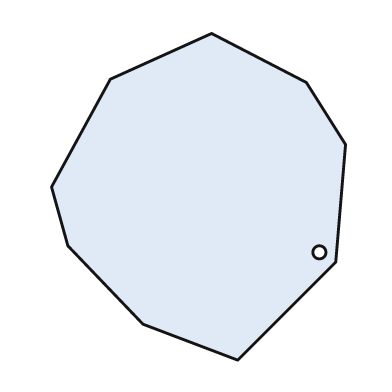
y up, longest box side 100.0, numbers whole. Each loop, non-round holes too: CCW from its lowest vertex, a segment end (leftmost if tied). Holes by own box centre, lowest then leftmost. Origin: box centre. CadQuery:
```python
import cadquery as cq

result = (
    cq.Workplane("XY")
    .moveTo(12.0, -50.0)
    .lineTo(42.0, -20.0)
    .lineTo(45.0, 16.0)
    .lineTo(33.0, 35.0)
    .lineTo(4.0, 50.0)
    .lineTo(-27.0, 36.0)
    .lineTo(-45.0, 3.0)
    .lineTo(-40.0, -15.0)
    .lineTo(-17.0, -39.0)
    .close()
    .moveTo(37.0, -17.0)
    .circle(2.0)
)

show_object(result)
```